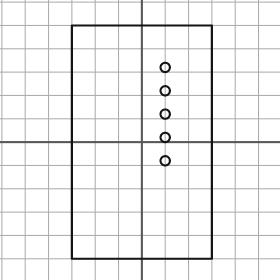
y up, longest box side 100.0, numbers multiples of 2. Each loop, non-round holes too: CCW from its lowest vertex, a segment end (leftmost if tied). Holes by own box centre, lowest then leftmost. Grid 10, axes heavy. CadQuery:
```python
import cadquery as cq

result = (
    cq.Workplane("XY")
    .moveTo(-30.0, -50.0)
    .lineTo(30.0, -50.0)
    .lineTo(30.0, 50.0)
    .lineTo(-30.0, 50.0)
    .close()
    .moveTo(10.0, -8.0)
    .circle(2.0)
    .moveTo(10.0, 2.0)
    .circle(2.0)
    .moveTo(10.0, 12.0)
    .circle(2.0)
    .moveTo(10.0, 22.0)
    .circle(2.0)
    .moveTo(10.0, 32.0)
    .circle(2.0)
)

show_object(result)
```